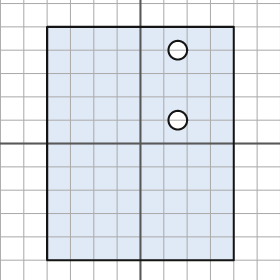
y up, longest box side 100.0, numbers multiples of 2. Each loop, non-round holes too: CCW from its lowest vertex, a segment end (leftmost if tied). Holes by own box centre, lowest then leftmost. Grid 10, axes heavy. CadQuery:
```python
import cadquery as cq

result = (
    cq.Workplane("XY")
    .moveTo(-40.0, -50.0)
    .lineTo(40.0, -50.0)
    .lineTo(40.0, 50.0)
    .lineTo(-40.0, 50.0)
    .close()
    .moveTo(16.0, 10.0)
    .circle(4.0)
    .moveTo(16.0, 40.0)
    .circle(4.0)
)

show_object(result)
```